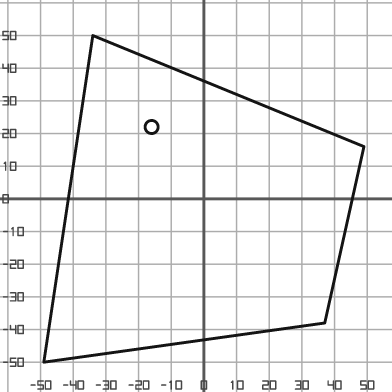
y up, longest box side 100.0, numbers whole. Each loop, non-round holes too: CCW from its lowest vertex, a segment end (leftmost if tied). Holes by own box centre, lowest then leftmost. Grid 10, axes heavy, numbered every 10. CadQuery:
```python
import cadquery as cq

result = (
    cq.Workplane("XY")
    .moveTo(-49.0, -50.0)
    .lineTo(37.0, -38.0)
    .lineTo(49.0, 16.0)
    .lineTo(-34.0, 50.0)
    .close()
    .moveTo(-16.0, 22.0)
    .circle(2.0)
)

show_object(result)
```